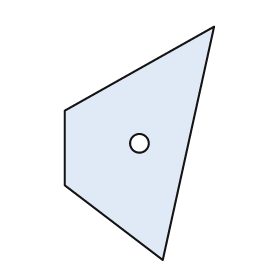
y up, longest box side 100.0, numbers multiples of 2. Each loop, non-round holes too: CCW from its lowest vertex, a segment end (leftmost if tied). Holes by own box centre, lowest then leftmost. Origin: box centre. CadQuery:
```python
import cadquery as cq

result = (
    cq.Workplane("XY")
    .moveTo(10.0, -50.0)
    .lineTo(32.0, 50.0)
    .lineTo(-32.0, 14.0)
    .lineTo(-32.0, -18.0)
    .close()
    .moveTo(0.0, 0.0)
    .circle(4.0)
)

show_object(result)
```